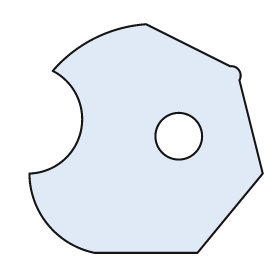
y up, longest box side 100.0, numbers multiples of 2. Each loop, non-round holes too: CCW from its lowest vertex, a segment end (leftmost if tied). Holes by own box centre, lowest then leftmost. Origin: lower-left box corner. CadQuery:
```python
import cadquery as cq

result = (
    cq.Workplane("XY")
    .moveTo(28.0, 0.0)
    .lineTo(72.0, 0.0)
    .lineTo(100.0, 34.0)
    .lineTo(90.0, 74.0)
    .threePointArc((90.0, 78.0), (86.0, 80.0))
    .lineTo(50.0, 98.0)
    .threePointArc((28.0, 92.0), (10.0, 78.0))
    .threePointArc((22.0, 52.0), (0.0, 34.0))
    .threePointArc((8.0, 12.0), (28.0, 0.0))
    .close()
    .moveTo(64.0, 50.0)
    .circle(10.0)
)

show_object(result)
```